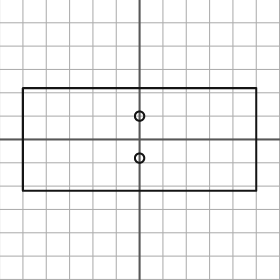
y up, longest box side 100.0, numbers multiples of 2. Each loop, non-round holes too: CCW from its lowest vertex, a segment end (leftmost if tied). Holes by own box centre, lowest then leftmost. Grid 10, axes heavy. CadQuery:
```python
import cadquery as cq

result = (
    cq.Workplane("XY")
    .moveTo(-50.0, -22.0)
    .lineTo(50.0, -22.0)
    .lineTo(50.0, 22.0)
    .lineTo(-50.0, 22.0)
    .close()
    .moveTo(0.0, -8.0)
    .circle(2.0)
    .moveTo(0.0, 10.0)
    .circle(2.0)
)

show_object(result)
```